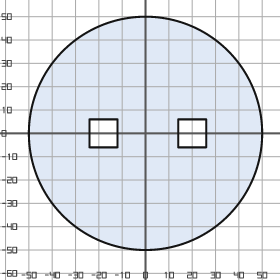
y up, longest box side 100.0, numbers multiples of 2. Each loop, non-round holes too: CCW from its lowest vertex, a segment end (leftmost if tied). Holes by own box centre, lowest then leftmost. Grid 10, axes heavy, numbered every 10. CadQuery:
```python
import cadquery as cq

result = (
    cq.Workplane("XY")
    .moveTo(0.0, 0.0)
    .circle(50.0)
    .moveTo(-24.0, -6.0)
    .lineTo(-12.0, -6.0)
    .lineTo(-12.0, 6.0)
    .lineTo(-24.0, 6.0)
    .close()
    .moveTo(14.0, -6.0)
    .lineTo(26.0, -6.0)
    .lineTo(26.0, 6.0)
    .lineTo(14.0, 6.0)
    .close()
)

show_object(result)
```